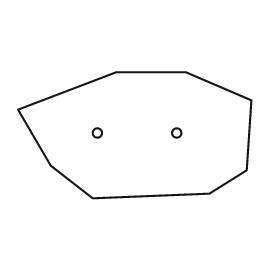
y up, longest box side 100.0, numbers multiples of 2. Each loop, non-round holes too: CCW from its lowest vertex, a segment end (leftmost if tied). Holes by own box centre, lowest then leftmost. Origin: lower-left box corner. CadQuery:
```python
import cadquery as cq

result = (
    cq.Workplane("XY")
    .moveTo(32.0, 0.0)
    .lineTo(82.0, 2.0)
    .lineTo(98.0, 12.0)
    .lineTo(100.0, 42.0)
    .lineTo(72.0, 54.0)
    .lineTo(42.0, 54.0)
    .lineTo(0.0, 38.0)
    .lineTo(14.0, 14.0)
    .close()
    .moveTo(34.0, 28.0)
    .circle(2.0)
    .moveTo(68.0, 28.0)
    .circle(2.0)
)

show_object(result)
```